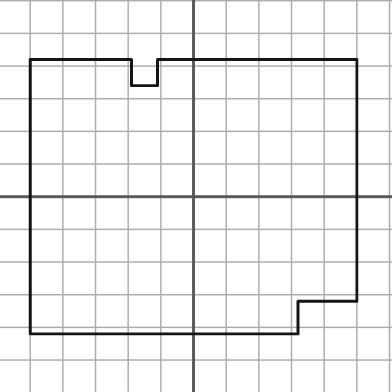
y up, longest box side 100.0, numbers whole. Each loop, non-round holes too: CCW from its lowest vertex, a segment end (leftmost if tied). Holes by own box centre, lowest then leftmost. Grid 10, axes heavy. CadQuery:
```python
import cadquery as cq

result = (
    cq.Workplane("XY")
    .moveTo(-50.0, -42.0)
    .lineTo(32.0, -42.0)
    .lineTo(32.0, -32.0)
    .lineTo(50.0, -32.0)
    .lineTo(50.0, 42.0)
    .lineTo(-11.0, 42.0)
    .lineTo(-11.0, 34.0)
    .lineTo(-19.0, 34.0)
    .lineTo(-19.0, 42.0)
    .lineTo(-50.0, 42.0)
    .close()
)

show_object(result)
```